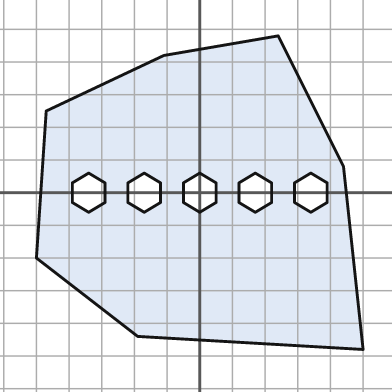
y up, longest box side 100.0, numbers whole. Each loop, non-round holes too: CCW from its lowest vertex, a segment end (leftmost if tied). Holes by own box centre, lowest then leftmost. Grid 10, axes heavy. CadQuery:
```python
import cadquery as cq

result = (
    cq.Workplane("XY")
    .moveTo(50.0, -48.0)
    .lineTo(44.0, 8.0)
    .lineTo(24.0, 48.0)
    .lineTo(-11.0, 42.0)
    .lineTo(-47.0, 25.0)
    .lineTo(-50.0, -20.0)
    .lineTo(-19.0, -44.0)
    .close()
    .moveTo(-34.0, -6.0)
    .lineTo(-29.0, -3.0)
    .lineTo(-29.0, 3.0)
    .lineTo(-34.0, 6.0)
    .lineTo(-39.0, 3.0)
    .lineTo(-39.0, -3.0)
    .close()
    .moveTo(-17.0, -6.0)
    .lineTo(-12.0, -3.0)
    .lineTo(-12.0, 3.0)
    .lineTo(-17.0, 6.0)
    .lineTo(-22.0, 3.0)
    .lineTo(-22.0, -3.0)
    .close()
    .moveTo(0.0, -6.0)
    .lineTo(5.0, -3.0)
    .lineTo(5.0, 3.0)
    .lineTo(0.0, 6.0)
    .lineTo(-5.0, 3.0)
    .lineTo(-5.0, -3.0)
    .close()
    .moveTo(17.0, -6.0)
    .lineTo(22.0, -3.0)
    .lineTo(22.0, 3.0)
    .lineTo(17.0, 6.0)
    .lineTo(12.0, 3.0)
    .lineTo(12.0, -3.0)
    .close()
    .moveTo(34.0, -6.0)
    .lineTo(39.0, -3.0)
    .lineTo(39.0, 3.0)
    .lineTo(34.0, 6.0)
    .lineTo(29.0, 3.0)
    .lineTo(29.0, -3.0)
    .close()
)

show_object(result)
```